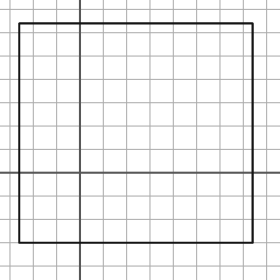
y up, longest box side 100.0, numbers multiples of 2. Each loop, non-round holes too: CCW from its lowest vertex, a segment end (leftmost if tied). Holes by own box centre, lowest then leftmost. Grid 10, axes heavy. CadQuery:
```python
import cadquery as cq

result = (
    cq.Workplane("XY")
    .moveTo(-26.0, -30.0)
    .lineTo(74.0, -30.0)
    .lineTo(74.0, 64.0)
    .lineTo(-26.0, 64.0)
    .close()
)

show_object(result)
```